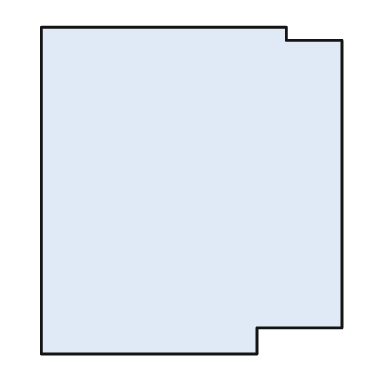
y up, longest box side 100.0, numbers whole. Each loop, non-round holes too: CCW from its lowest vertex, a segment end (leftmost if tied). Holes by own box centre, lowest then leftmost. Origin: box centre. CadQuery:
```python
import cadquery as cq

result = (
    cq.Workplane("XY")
    .moveTo(-46.0, -50.0)
    .lineTo(20.0, -50.0)
    .lineTo(20.0, -42.0)
    .lineTo(46.0, -42.0)
    .lineTo(46.0, 46.0)
    .lineTo(29.0, 46.0)
    .lineTo(29.0, 50.0)
    .lineTo(-46.0, 50.0)
    .close()
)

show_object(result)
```